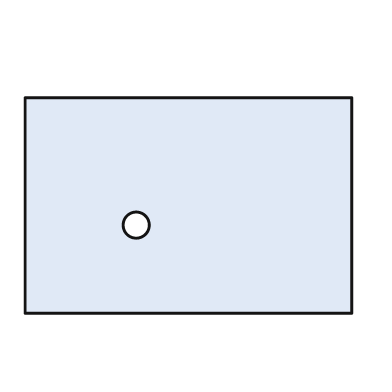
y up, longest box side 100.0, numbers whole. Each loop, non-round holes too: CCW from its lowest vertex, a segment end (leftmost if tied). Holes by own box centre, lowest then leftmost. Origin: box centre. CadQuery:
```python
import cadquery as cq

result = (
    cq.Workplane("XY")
    .moveTo(-50.0, -33.0)
    .lineTo(50.0, -33.0)
    .lineTo(50.0, 33.0)
    .lineTo(-50.0, 33.0)
    .close()
    .moveTo(-16.0, -6.0)
    .circle(4.0)
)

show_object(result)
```